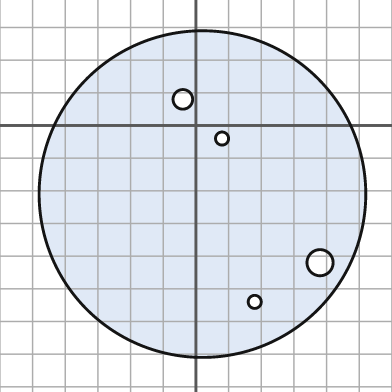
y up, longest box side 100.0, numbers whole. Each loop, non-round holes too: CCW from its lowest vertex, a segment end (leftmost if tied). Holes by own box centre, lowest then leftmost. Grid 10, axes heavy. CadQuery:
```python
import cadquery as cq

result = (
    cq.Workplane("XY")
    .moveTo(2.0, -21.0)
    .circle(50.0)
    .moveTo(18.0, -54.0)
    .circle(2.0)
    .moveTo(38.0, -42.0)
    .circle(4.0)
    .moveTo(8.0, -4.0)
    .circle(2.0)
    .moveTo(-4.0, 8.0)
    .circle(3.0)
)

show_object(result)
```